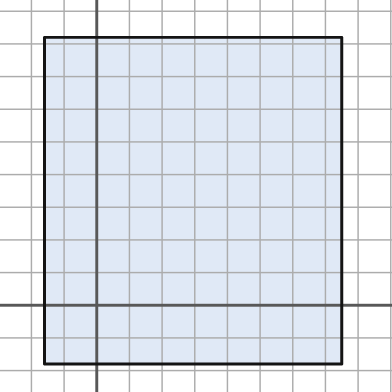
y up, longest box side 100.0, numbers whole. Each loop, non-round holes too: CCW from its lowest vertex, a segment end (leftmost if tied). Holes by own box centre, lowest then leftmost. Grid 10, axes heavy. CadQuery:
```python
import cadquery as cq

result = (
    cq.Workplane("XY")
    .moveTo(-16.0, -18.0)
    .lineTo(75.0, -18.0)
    .lineTo(75.0, 82.0)
    .lineTo(-16.0, 82.0)
    .close()
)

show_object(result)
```